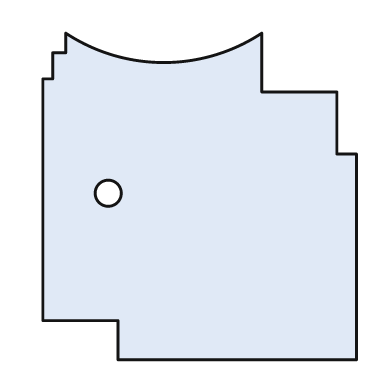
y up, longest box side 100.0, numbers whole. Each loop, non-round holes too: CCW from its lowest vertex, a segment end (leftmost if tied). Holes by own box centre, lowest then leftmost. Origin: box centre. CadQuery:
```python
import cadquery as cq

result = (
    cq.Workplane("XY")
    .moveTo(-25.0, -50.0)
    .lineTo(48.0, -50.0)
    .lineTo(48.0, 13.0)
    .lineTo(42.0, 13.0)
    .lineTo(42.0, 32.0)
    .lineTo(19.0, 32.0)
    .lineTo(19.0, 50.0)
    .threePointArc((-11.0, 41.0), (-41.0, 50.0))
    .lineTo(-41.0, 44.0)
    .lineTo(-45.0, 44.0)
    .lineTo(-45.0, 36.0)
    .lineTo(-48.0, 36.0)
    .lineTo(-48.0, -38.0)
    .lineTo(-25.0, -38.0)
    .close()
    .moveTo(-28.0, 1.0)
    .circle(4.0)
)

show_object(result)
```